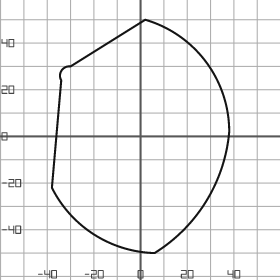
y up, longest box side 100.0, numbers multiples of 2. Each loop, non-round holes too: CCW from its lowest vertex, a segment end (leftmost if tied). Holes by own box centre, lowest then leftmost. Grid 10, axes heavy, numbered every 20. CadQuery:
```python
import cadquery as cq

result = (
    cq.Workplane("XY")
    .moveTo(6.0, -50.0)
    .threePointArc((28.0, -28.0), (38.0, 2.0))
    .threePointArc((28.0, 32.0), (2.0, 50.0))
    .lineTo(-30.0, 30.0)
    .threePointArc((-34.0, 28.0), (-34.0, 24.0))
    .lineTo(-38.0, -22.0)
    .threePointArc((-20.0, -42.0), (6.0, -50.0))
    .close()
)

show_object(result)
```